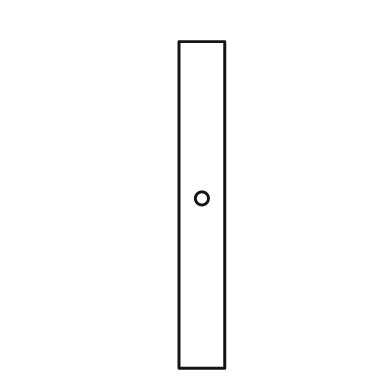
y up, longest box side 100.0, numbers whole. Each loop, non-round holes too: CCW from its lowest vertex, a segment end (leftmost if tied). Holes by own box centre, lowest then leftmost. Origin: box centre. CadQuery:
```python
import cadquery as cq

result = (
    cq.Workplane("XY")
    .moveTo(-7.0, -50.0)
    .lineTo(7.0, -50.0)
    .lineTo(7.0, 50.0)
    .lineTo(-7.0, 50.0)
    .close()
    .moveTo(0.0, 2.0)
    .circle(2.0)
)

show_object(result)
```